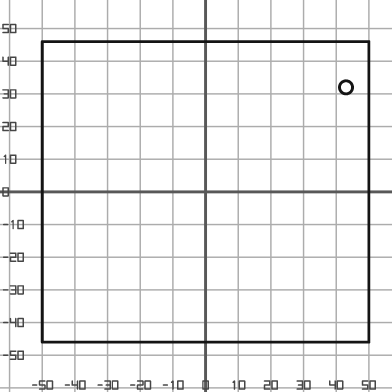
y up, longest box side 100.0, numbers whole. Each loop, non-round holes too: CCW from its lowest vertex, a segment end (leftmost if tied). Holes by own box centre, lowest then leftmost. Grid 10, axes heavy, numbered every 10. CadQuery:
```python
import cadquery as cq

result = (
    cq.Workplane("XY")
    .moveTo(-50.0, -46.0)
    .lineTo(50.0, -46.0)
    .lineTo(50.0, 46.0)
    .lineTo(-50.0, 46.0)
    .close()
    .moveTo(43.0, 32.0)
    .circle(2.0)
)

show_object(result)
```